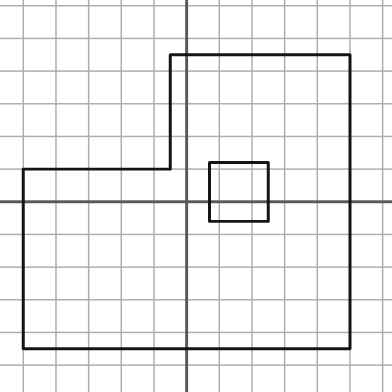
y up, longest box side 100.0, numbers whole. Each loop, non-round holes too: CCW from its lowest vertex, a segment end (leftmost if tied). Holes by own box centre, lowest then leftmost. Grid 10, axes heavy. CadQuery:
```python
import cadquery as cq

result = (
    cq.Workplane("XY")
    .moveTo(-50.0, -45.0)
    .lineTo(50.0, -45.0)
    .lineTo(50.0, 45.0)
    .lineTo(-5.0, 45.0)
    .lineTo(-5.0, 10.0)
    .lineTo(-50.0, 10.0)
    .close()
    .moveTo(7.0, -6.0)
    .lineTo(25.0, -6.0)
    .lineTo(25.0, 12.0)
    .lineTo(7.0, 12.0)
    .close()
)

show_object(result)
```